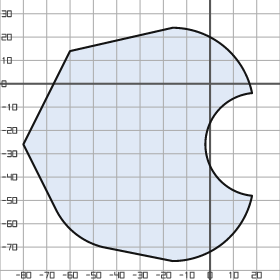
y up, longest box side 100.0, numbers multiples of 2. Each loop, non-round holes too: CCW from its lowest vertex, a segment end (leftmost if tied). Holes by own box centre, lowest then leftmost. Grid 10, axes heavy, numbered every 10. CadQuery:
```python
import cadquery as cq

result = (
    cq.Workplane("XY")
    .moveTo(-16.0, -76.0)
    .threePointArc((6.0, -68.0), (18.0, -48.0))
    .threePointArc((-2.0, -26.0), (18.0, -4.0))
    .threePointArc((6.0, 16.0), (-16.0, 24.0))
    .lineTo(-60.0, 14.0)
    .lineTo(-80.0, -26.0)
    .lineTo(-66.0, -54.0)
    .threePointArc((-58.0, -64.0), (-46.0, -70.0))
    .close()
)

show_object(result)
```